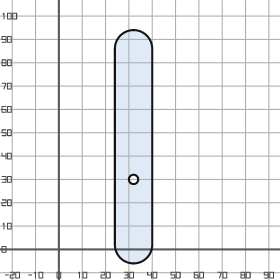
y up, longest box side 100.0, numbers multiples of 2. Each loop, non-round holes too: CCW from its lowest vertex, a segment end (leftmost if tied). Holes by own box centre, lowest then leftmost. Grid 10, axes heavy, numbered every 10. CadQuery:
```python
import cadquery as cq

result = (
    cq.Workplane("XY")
    .moveTo(24.0, 2.0)
    .threePointArc((32.0, -6.0), (40.0, 2.0))
    .lineTo(40.0, 86.0)
    .threePointArc((32.0, 94.0), (24.0, 86.0))
    .close()
    .moveTo(32.0, 30.0)
    .circle(2.0)
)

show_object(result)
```